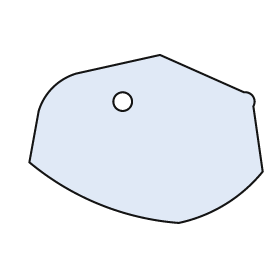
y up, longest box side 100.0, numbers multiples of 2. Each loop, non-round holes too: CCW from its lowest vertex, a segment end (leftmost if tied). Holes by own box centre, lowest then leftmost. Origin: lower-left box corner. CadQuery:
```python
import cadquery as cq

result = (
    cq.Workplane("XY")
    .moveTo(64.0, 0.0)
    .threePointArc((84.0, 8.0), (100.0, 22.0))
    .lineTo(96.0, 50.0)
    .threePointArc((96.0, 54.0), (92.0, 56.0))
    .lineTo(56.0, 72.0)
    .lineTo(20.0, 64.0)
    .threePointArc((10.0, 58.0), (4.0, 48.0))
    .lineTo(0.0, 26.0)
    .threePointArc((30.0, 8.0), (64.0, 0.0))
    .close()
    .moveTo(40.0, 52.0)
    .circle(4.0)
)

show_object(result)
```